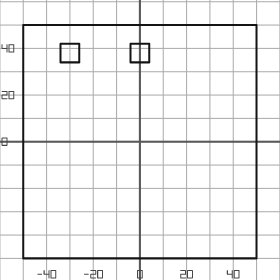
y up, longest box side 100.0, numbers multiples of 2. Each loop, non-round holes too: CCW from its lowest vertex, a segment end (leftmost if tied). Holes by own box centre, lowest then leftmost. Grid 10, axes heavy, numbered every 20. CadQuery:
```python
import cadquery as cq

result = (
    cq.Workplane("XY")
    .moveTo(-50.0, -50.0)
    .lineTo(50.0, -50.0)
    .lineTo(50.0, 50.0)
    .lineTo(-50.0, 50.0)
    .close()
    .moveTo(-34.0, 34.0)
    .lineTo(-26.0, 34.0)
    .lineTo(-26.0, 42.0)
    .lineTo(-34.0, 42.0)
    .close()
    .moveTo(-4.0, 34.0)
    .lineTo(4.0, 34.0)
    .lineTo(4.0, 42.0)
    .lineTo(-4.0, 42.0)
    .close()
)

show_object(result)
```